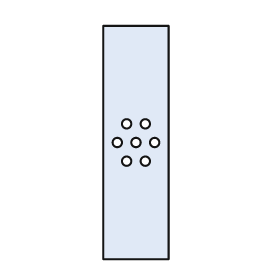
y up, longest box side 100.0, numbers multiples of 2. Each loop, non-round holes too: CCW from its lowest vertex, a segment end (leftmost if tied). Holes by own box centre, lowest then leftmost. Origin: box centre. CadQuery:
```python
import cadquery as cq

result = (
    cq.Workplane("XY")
    .moveTo(-14.0, -50.0)
    .lineTo(14.0, -50.0)
    .lineTo(14.0, 50.0)
    .lineTo(-14.0, 50.0)
    .close()
    .moveTo(-4.0, -8.0)
    .circle(2.0)
    .moveTo(4.0, -8.0)
    .circle(2.0)
    .moveTo(-8.0, 0.0)
    .circle(2.0)
    .moveTo(0.0, 0.0)
    .circle(2.0)
    .moveTo(8.0, 0.0)
    .circle(2.0)
    .moveTo(-4.0, 8.0)
    .circle(2.0)
    .moveTo(4.0, 8.0)
    .circle(2.0)
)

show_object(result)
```